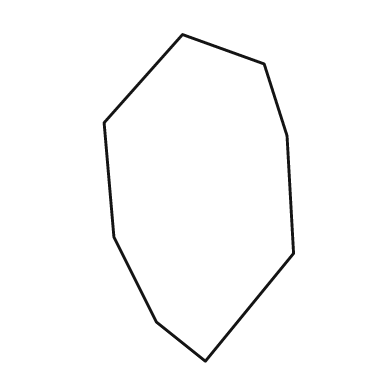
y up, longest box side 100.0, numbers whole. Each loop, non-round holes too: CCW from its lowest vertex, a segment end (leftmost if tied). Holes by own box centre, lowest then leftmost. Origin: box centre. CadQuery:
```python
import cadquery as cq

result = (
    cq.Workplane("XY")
    .moveTo(2.0, -50.0)
    .lineTo(29.0, -17.0)
    .lineTo(27.0, 19.0)
    .lineTo(20.0, 41.0)
    .lineTo(-5.0, 50.0)
    .lineTo(-29.0, 23.0)
    .lineTo(-26.0, -12.0)
    .lineTo(-13.0, -38.0)
    .close()
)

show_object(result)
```